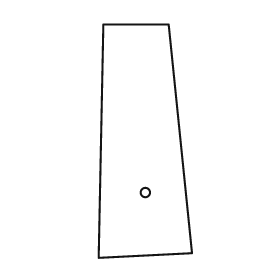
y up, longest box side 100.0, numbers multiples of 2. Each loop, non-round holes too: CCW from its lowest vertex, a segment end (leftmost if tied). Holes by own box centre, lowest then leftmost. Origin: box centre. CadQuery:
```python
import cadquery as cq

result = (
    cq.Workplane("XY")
    .moveTo(-20.0, -50.0)
    .lineTo(20.0, -48.0)
    .lineTo(10.0, 50.0)
    .lineTo(-18.0, 50.0)
    .close()
    .moveTo(0.0, -22.0)
    .circle(2.0)
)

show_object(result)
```